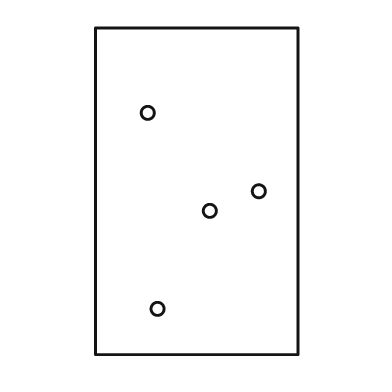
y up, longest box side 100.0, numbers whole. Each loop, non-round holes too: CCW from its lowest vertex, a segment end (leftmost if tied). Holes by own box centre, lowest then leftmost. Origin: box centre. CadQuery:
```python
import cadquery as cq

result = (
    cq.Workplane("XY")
    .moveTo(-31.0, -50.0)
    .lineTo(31.0, -50.0)
    .lineTo(31.0, 50.0)
    .lineTo(-31.0, 50.0)
    .close()
    .moveTo(-12.0, -36.0)
    .circle(2.0)
    .moveTo(4.0, -6.0)
    .circle(2.0)
    .moveTo(19.0, 0.0)
    .circle(2.0)
    .moveTo(-15.0, 24.0)
    .circle(2.0)
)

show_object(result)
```